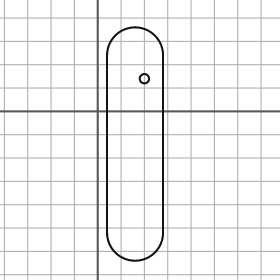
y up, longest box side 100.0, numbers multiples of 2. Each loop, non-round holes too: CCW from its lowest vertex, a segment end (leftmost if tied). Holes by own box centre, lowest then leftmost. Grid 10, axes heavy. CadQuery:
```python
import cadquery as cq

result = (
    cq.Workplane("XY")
    .moveTo(4.0, -52.0)
    .threePointArc((16.0, -64.0), (28.0, -52.0))
    .lineTo(28.0, 24.0)
    .threePointArc((16.0, 36.0), (4.0, 24.0))
    .close()
    .moveTo(20.0, 14.0)
    .circle(2.0)
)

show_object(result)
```